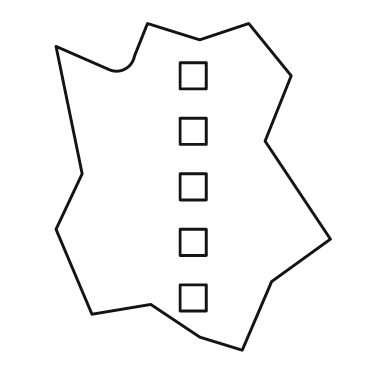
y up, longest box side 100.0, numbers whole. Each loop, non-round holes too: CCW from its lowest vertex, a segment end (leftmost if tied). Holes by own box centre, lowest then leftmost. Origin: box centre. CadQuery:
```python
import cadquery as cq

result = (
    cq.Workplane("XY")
    .moveTo(15.0, -50.0)
    .lineTo(24.0, -29.0)
    .lineTo(42.0, -16.0)
    .lineTo(22.0, 14.0)
    .lineTo(30.0, 34.0)
    .lineTo(17.0, 50.0)
    .lineTo(2.0, 45.0)
    .lineTo(-14.0, 50.0)
    .lineTo(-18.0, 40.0)
    .threePointArc((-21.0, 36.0), (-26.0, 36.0))
    .lineTo(-42.0, 43.0)
    .lineTo(-34.0, 4.0)
    .lineTo(-42.0, -13.0)
    .lineTo(-31.0, -39.0)
    .lineTo(-13.0, -36.0)
    .lineTo(2.0, -46.0)
    .close()
    .moveTo(-4.0, -38.0)
    .lineTo(4.0, -38.0)
    .lineTo(4.0, -30.0)
    .lineTo(-4.0, -30.0)
    .close()
    .moveTo(-4.0, -21.0)
    .lineTo(4.0, -21.0)
    .lineTo(4.0, -13.0)
    .lineTo(-4.0, -13.0)
    .close()
    .moveTo(-4.0, -4.0)
    .lineTo(4.0, -4.0)
    .lineTo(4.0, 4.0)
    .lineTo(-4.0, 4.0)
    .close()
    .moveTo(-4.0, 13.0)
    .lineTo(4.0, 13.0)
    .lineTo(4.0, 21.0)
    .lineTo(-4.0, 21.0)
    .close()
    .moveTo(-4.0, 30.0)
    .lineTo(4.0, 30.0)
    .lineTo(4.0, 38.0)
    .lineTo(-4.0, 38.0)
    .close()
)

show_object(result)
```